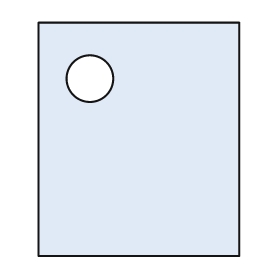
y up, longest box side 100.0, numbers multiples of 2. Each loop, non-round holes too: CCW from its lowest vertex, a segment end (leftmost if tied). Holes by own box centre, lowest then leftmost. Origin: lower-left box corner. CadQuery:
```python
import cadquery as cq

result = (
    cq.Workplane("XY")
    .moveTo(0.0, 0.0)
    .lineTo(86.0, 0.0)
    .lineTo(86.0, 100.0)
    .lineTo(0.0, 100.0)
    .close()
    .moveTo(22.0, 76.0)
    .circle(10.0)
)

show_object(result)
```